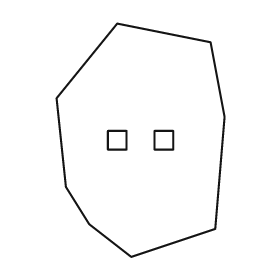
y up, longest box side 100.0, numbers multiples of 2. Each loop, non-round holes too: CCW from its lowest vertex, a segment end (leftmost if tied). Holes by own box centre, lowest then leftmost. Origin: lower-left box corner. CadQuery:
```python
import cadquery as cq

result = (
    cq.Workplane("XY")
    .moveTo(32.0, 0.0)
    .lineTo(68.0, 12.0)
    .lineTo(72.0, 60.0)
    .lineTo(66.0, 92.0)
    .lineTo(26.0, 100.0)
    .lineTo(0.0, 68.0)
    .lineTo(4.0, 30.0)
    .lineTo(14.0, 14.0)
    .close()
    .moveTo(22.0, 46.0)
    .lineTo(30.0, 46.0)
    .lineTo(30.0, 54.0)
    .lineTo(22.0, 54.0)
    .close()
    .moveTo(42.0, 46.0)
    .lineTo(50.0, 46.0)
    .lineTo(50.0, 54.0)
    .lineTo(42.0, 54.0)
    .close()
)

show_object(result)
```